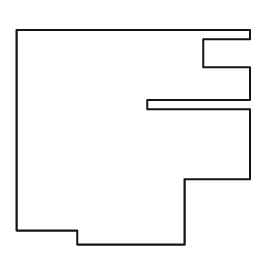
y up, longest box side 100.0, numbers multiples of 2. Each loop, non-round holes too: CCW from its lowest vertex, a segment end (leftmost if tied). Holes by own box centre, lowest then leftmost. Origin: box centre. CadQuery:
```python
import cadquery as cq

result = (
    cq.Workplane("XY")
    .moveTo(-24.0, -46.0)
    .lineTo(22.0, -46.0)
    .lineTo(22.0, -18.0)
    .lineTo(50.0, -18.0)
    .lineTo(50.0, 12.0)
    .lineTo(6.0, 12.0)
    .lineTo(6.0, 16.0)
    .lineTo(50.0, 16.0)
    .lineTo(50.0, 30.0)
    .lineTo(30.0, 30.0)
    .lineTo(30.0, 42.0)
    .lineTo(50.0, 42.0)
    .lineTo(50.0, 46.0)
    .lineTo(-50.0, 46.0)
    .lineTo(-50.0, -40.0)
    .lineTo(-24.0, -40.0)
    .close()
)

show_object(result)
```